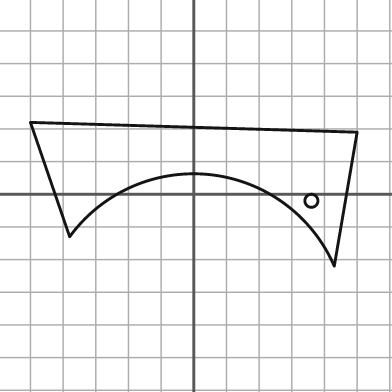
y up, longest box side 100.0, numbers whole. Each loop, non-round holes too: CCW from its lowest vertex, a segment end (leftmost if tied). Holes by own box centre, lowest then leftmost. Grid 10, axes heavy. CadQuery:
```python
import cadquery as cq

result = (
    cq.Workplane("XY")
    .moveTo(43.0, -22.0)
    .lineTo(50.0, 19.0)
    .lineTo(-50.0, 22.0)
    .lineTo(-38.0, -13.0)
    .threePointArc((5.0, 6.0), (43.0, -22.0))
    .close()
    .moveTo(36.0, -2.0)
    .circle(2.0)
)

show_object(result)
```